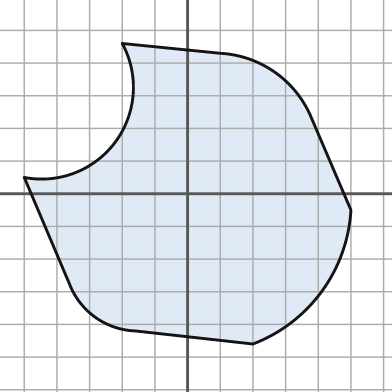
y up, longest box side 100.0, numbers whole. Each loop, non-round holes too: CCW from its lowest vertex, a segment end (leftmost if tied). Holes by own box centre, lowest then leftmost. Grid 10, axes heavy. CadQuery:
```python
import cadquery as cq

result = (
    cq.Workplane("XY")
    .moveTo(20.0, -46.0)
    .threePointArc((41.0, -30.0), (50.0, -5.0))
    .lineTo(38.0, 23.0)
    .threePointArc((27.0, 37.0), (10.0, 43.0))
    .lineTo(-20.0, 46.0)
    .threePointArc((-22.0, 16.0), (-50.0, 5.0))
    .lineTo(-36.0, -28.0)
    .threePointArc((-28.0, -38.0), (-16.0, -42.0))
    .close()
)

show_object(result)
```